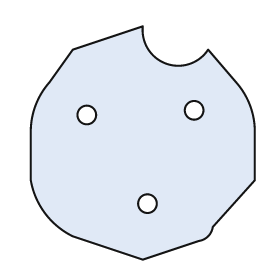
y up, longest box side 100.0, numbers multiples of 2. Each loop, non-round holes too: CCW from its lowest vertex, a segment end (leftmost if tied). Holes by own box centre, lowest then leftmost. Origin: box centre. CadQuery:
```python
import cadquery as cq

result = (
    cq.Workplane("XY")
    .moveTo(0.0, -50.0)
    .lineTo(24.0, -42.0)
    .threePointArc((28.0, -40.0), (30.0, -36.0))
    .lineTo(48.0, -16.0)
    .lineTo(48.0, 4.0)
    .threePointArc((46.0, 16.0), (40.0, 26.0))
    .lineTo(28.0, 40.0)
    .threePointArc((10.0, 34.0), (0.0, 50.0))
    .lineTo(-30.0, 40.0)
    .lineTo(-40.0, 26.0)
    .threePointArc((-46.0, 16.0), (-48.0, 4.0))
    .lineTo(-48.0, -16.0)
    .threePointArc((-42.0, -30.0), (-30.0, -40.0))
    .close()
    .moveTo(2.0, -26.0)
    .circle(4.0)
    .moveTo(-24.0, 12.0)
    .circle(4.0)
    .moveTo(22.0, 14.0)
    .circle(4.0)
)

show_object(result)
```